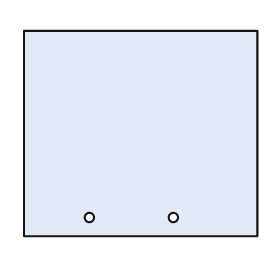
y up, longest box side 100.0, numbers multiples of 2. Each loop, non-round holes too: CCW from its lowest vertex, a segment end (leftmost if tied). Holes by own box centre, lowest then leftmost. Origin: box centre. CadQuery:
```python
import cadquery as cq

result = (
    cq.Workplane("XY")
    .moveTo(-50.0, -44.0)
    .lineTo(50.0, -44.0)
    .lineTo(50.0, 44.0)
    .lineTo(-50.0, 44.0)
    .close()
    .moveTo(-22.0, -36.0)
    .circle(2.0)
    .moveTo(14.0, -36.0)
    .circle(2.0)
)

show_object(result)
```